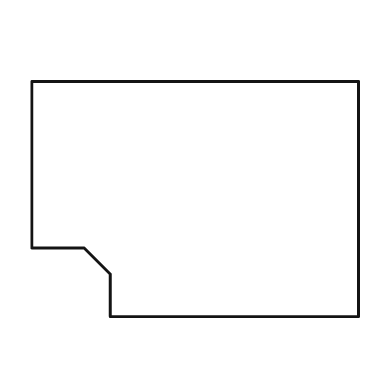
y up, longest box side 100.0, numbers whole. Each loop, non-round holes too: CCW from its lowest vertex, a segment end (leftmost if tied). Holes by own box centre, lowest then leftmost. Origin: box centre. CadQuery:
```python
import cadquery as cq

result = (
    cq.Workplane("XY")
    .moveTo(-26.0, -36.0)
    .lineTo(50.0, -36.0)
    .lineTo(50.0, 36.0)
    .lineTo(-50.0, 36.0)
    .lineTo(-50.0, -15.0)
    .lineTo(-34.0, -15.0)
    .lineTo(-26.0, -23.0)
    .close()
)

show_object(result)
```